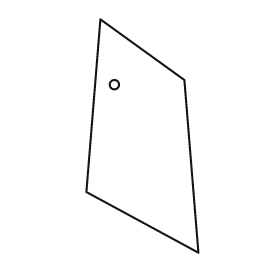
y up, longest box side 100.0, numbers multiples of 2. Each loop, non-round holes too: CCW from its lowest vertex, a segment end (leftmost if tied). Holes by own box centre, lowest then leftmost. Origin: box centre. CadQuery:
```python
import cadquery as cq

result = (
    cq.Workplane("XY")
    .moveTo(24.0, -50.0)
    .lineTo(18.0, 24.0)
    .lineTo(-18.0, 50.0)
    .lineTo(-24.0, -24.0)
    .close()
    .moveTo(-12.0, 22.0)
    .circle(2.0)
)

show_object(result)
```